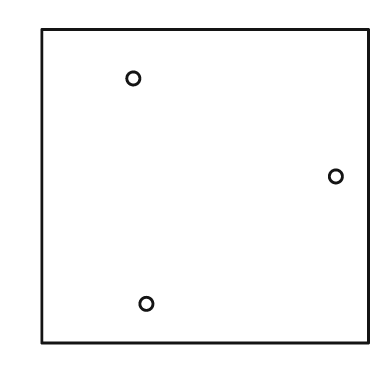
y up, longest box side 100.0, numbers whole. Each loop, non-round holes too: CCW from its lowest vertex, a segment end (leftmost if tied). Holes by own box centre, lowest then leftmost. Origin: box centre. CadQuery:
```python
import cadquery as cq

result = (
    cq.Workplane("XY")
    .moveTo(-50.0, -48.0)
    .lineTo(50.0, -48.0)
    .lineTo(50.0, 48.0)
    .lineTo(-50.0, 48.0)
    .close()
    .moveTo(-18.0, -36.0)
    .circle(2.0)
    .moveTo(40.0, 3.0)
    .circle(2.0)
    .moveTo(-22.0, 33.0)
    .circle(2.0)
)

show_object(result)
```